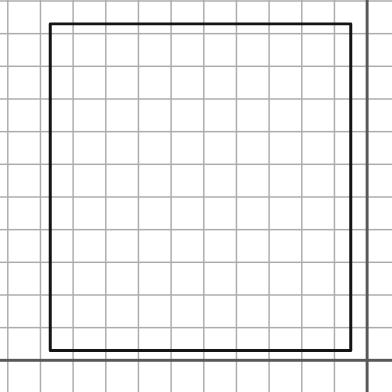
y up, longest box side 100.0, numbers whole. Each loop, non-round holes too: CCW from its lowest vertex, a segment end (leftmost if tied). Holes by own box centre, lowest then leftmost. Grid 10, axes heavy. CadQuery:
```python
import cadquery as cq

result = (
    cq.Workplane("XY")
    .moveTo(-97.0, 3.0)
    .lineTo(-5.0, 3.0)
    .lineTo(-5.0, 103.0)
    .lineTo(-97.0, 103.0)
    .close()
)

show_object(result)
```